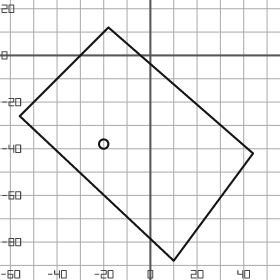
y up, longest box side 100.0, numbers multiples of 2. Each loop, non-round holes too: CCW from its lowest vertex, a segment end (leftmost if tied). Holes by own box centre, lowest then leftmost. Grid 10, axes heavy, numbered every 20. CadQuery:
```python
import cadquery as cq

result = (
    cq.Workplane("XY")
    .moveTo(10.0, -88.0)
    .lineTo(44.0, -42.0)
    .lineTo(-18.0, 12.0)
    .lineTo(-56.0, -26.0)
    .close()
    .moveTo(-20.0, -38.0)
    .circle(2.0)
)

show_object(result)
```